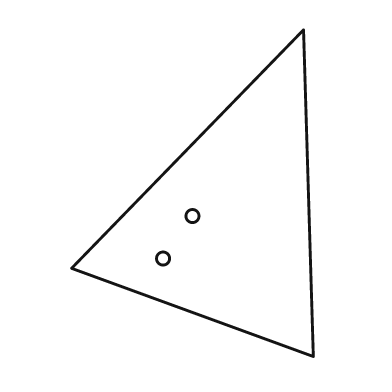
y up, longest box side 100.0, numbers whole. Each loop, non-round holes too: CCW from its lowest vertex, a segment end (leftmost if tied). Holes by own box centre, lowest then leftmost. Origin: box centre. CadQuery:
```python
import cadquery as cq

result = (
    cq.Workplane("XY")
    .moveTo(37.0, -50.0)
    .lineTo(34.0, 50.0)
    .lineTo(-37.0, -23.0)
    .close()
    .moveTo(-9.0, -20.0)
    .circle(2.0)
    .moveTo(0.0, -7.0)
    .circle(2.0)
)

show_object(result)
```